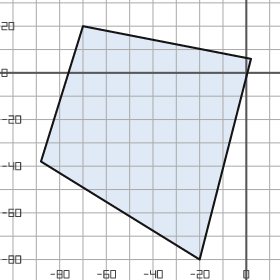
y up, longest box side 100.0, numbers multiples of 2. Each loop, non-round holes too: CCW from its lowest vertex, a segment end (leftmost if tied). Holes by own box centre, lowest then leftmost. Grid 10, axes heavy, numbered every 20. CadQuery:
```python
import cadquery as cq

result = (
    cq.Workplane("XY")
    .moveTo(-20.0, -80.0)
    .lineTo(2.0, 6.0)
    .lineTo(-70.0, 20.0)
    .lineTo(-88.0, -38.0)
    .close()
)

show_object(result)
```